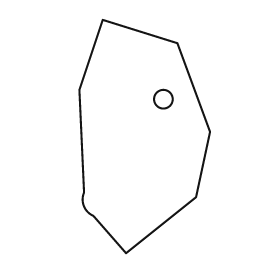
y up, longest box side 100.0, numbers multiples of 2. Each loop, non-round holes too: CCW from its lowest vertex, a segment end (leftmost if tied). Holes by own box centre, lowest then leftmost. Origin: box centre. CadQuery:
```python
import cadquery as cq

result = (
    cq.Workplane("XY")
    .moveTo(-8.0, -50.0)
    .lineTo(22.0, -26.0)
    .lineTo(28.0, 2.0)
    .lineTo(14.0, 40.0)
    .lineTo(-18.0, 50.0)
    .lineTo(-28.0, 20.0)
    .lineTo(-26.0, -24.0)
    .threePointArc((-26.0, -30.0), (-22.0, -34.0))
    .close()
    .moveTo(8.0, 16.0)
    .circle(4.0)
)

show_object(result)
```